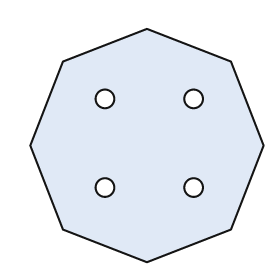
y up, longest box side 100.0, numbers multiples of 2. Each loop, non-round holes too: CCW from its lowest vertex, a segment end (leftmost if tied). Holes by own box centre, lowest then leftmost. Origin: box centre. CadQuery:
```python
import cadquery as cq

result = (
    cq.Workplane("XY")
    .moveTo(0.0, -50.0)
    .lineTo(36.0, -36.0)
    .lineTo(50.0, 0.0)
    .lineTo(36.0, 36.0)
    .lineTo(0.0, 50.0)
    .lineTo(-36.0, 36.0)
    .lineTo(-50.0, 0.0)
    .lineTo(-36.0, -36.0)
    .close()
    .moveTo(-18.0, -18.0)
    .circle(4.0)
    .moveTo(20.0, -18.0)
    .circle(4.0)
    .moveTo(-18.0, 20.0)
    .circle(4.0)
    .moveTo(20.0, 20.0)
    .circle(4.0)
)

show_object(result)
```